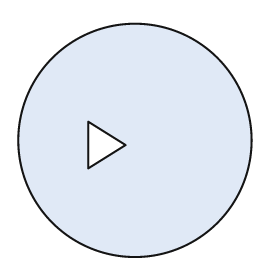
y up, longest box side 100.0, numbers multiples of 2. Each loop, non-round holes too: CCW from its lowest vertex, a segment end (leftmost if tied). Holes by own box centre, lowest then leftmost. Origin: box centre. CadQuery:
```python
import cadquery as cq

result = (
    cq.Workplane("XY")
    .moveTo(0.0, 0.0)
    .circle(50.0)
    .moveTo(-20.0, -12.0)
    .lineTo(-4.0, -2.0)
    .lineTo(-20.0, 8.0)
    .close()
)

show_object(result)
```